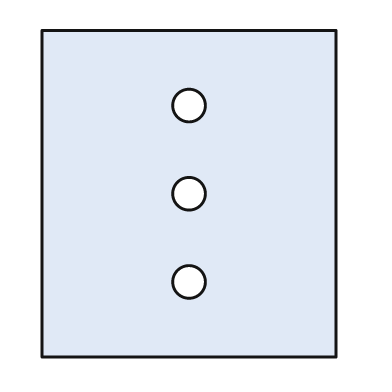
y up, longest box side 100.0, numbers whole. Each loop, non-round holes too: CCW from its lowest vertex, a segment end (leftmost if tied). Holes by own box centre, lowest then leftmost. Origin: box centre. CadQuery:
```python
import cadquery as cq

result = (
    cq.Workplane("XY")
    .moveTo(-45.0, -50.0)
    .lineTo(45.0, -50.0)
    .lineTo(45.0, 50.0)
    .lineTo(-45.0, 50.0)
    .close()
    .moveTo(0.0, -27.0)
    .circle(5.0)
    .moveTo(0.0, 0.0)
    .circle(5.0)
    .moveTo(0.0, 27.0)
    .circle(5.0)
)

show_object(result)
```